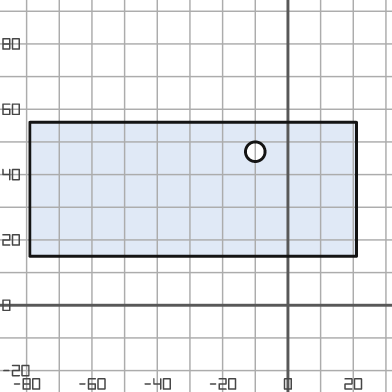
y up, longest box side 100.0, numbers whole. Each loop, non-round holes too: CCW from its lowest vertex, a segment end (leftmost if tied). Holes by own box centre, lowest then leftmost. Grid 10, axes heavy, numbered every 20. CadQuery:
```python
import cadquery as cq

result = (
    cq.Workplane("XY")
    .moveTo(-79.0, 15.0)
    .lineTo(21.0, 15.0)
    .lineTo(21.0, 56.0)
    .lineTo(-79.0, 56.0)
    .close()
    .moveTo(-10.0, 47.0)
    .circle(3.0)
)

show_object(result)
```